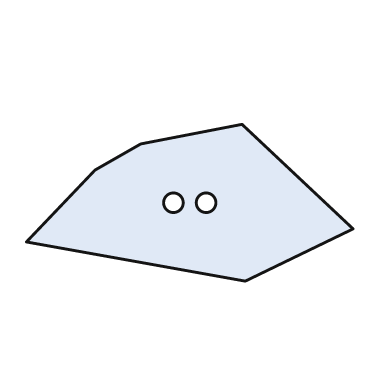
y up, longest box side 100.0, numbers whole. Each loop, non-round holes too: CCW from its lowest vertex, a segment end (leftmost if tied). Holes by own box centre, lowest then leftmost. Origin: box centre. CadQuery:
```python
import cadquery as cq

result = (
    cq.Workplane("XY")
    .moveTo(17.0, -24.0)
    .lineTo(50.0, -8.0)
    .lineTo(16.0, 24.0)
    .lineTo(-15.0, 18.0)
    .lineTo(-29.0, 10.0)
    .lineTo(-50.0, -12.0)
    .close()
    .moveTo(-5.0, 0.0)
    .circle(3.0)
    .moveTo(5.0, 0.0)
    .circle(3.0)
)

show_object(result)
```